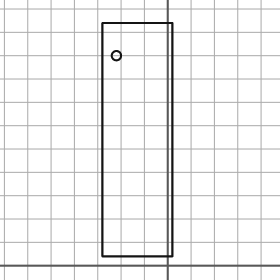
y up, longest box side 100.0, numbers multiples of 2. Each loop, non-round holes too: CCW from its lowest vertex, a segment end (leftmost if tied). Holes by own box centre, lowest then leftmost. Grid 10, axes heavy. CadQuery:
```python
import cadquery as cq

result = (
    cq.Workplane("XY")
    .moveTo(-28.0, 4.0)
    .lineTo(2.0, 4.0)
    .lineTo(2.0, 104.0)
    .lineTo(-28.0, 104.0)
    .close()
    .moveTo(-22.0, 90.0)
    .circle(2.0)
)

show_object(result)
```